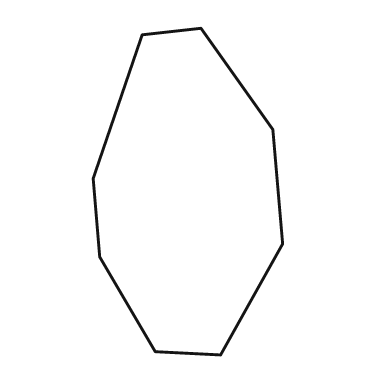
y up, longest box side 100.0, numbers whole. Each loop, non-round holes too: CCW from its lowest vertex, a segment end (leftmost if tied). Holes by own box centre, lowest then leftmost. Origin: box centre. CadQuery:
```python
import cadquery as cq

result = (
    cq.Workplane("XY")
    .moveTo(10.0, -50.0)
    .lineTo(29.0, -16.0)
    .lineTo(26.0, 19.0)
    .lineTo(4.0, 50.0)
    .lineTo(-14.0, 48.0)
    .lineTo(-29.0, 4.0)
    .lineTo(-27.0, -20.0)
    .lineTo(-10.0, -49.0)
    .close()
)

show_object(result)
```